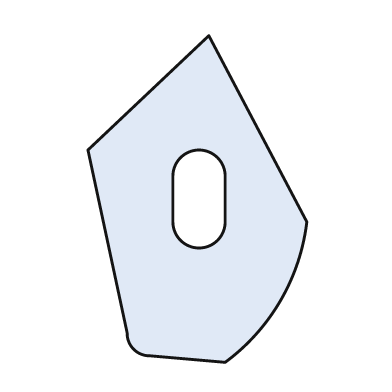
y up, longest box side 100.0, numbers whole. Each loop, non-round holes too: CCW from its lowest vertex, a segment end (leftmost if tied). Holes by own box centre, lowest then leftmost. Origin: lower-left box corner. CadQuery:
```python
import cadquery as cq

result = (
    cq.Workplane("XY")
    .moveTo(42.0, 0.0)
    .threePointArc((59.0, 19.0), (67.0, 43.0))
    .lineTo(37.0, 100.0)
    .lineTo(0.0, 65.0)
    .lineTo(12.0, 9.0)
    .threePointArc((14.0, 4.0), (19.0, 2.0))
    .close()
    .moveTo(26.0, 43.0)
    .threePointArc((34.0, 35.0), (42.0, 43.0))
    .lineTo(42.0, 57.0)
    .threePointArc((34.0, 65.0), (26.0, 57.0))
    .close()
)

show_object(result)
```